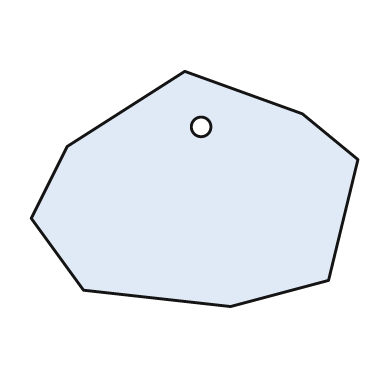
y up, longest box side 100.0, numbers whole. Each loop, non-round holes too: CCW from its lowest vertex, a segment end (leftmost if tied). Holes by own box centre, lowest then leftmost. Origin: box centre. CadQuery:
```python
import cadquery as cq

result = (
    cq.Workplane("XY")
    .moveTo(11.0, -36.0)
    .lineTo(41.0, -28.0)
    .lineTo(50.0, 9.0)
    .lineTo(33.0, 23.0)
    .lineTo(-3.0, 36.0)
    .lineTo(-39.0, 13.0)
    .lineTo(-50.0, -9.0)
    .lineTo(-34.0, -31.0)
    .close()
    .moveTo(2.0, 19.0)
    .circle(3.0)
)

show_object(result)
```